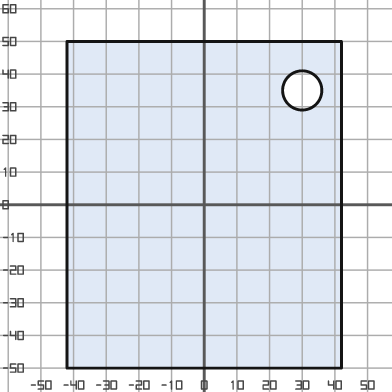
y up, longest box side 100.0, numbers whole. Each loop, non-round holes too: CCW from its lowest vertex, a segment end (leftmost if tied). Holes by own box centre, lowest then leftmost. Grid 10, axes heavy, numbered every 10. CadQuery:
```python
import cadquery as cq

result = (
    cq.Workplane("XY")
    .moveTo(-42.0, -50.0)
    .lineTo(42.0, -50.0)
    .lineTo(42.0, 50.0)
    .lineTo(-42.0, 50.0)
    .close()
    .moveTo(30.0, 35.0)
    .circle(6.0)
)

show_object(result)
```